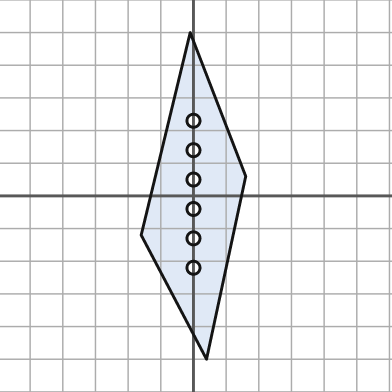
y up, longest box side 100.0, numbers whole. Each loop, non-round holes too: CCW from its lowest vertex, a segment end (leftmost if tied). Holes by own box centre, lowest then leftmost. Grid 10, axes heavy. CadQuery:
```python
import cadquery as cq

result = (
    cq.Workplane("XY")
    .moveTo(4.0, -50.0)
    .lineTo(16.0, 6.0)
    .lineTo(-1.0, 50.0)
    .lineTo(-16.0, -12.0)
    .close()
    .moveTo(0.0, -22.0)
    .circle(2.0)
    .moveTo(0.0, -13.0)
    .circle(2.0)
    .moveTo(0.0, -4.0)
    .circle(2.0)
    .moveTo(0.0, 5.0)
    .circle(2.0)
    .moveTo(0.0, 14.0)
    .circle(2.0)
    .moveTo(0.0, 23.0)
    .circle(2.0)
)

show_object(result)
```